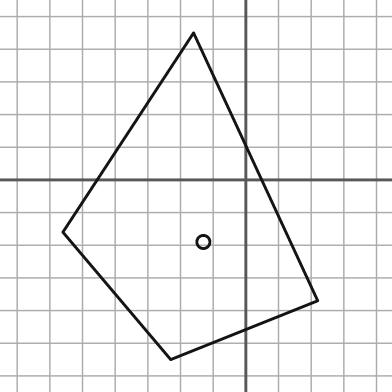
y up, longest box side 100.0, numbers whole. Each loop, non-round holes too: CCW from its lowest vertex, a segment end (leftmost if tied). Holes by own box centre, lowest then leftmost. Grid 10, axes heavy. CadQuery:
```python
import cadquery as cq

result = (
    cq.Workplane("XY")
    .moveTo(-23.0, -55.0)
    .lineTo(22.0, -37.0)
    .lineTo(-16.0, 45.0)
    .lineTo(-56.0, -16.0)
    .close()
    .moveTo(-13.0, -19.0)
    .circle(2.0)
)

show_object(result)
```